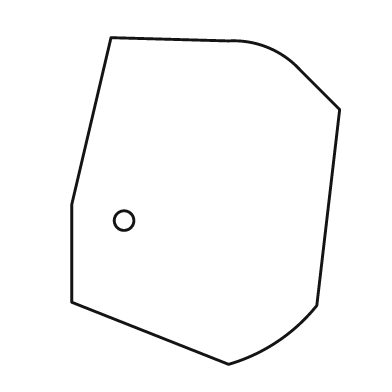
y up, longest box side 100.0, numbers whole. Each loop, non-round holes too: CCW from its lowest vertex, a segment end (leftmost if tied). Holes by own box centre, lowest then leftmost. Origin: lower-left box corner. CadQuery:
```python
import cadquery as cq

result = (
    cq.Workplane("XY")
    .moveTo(48.0, 0.0)
    .threePointArc((63.0, 7.0), (75.0, 18.0))
    .lineTo(82.0, 78.0)
    .lineTo(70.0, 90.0)
    .threePointArc((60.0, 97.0), (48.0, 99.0))
    .lineTo(12.0, 100.0)
    .lineTo(0.0, 49.0)
    .lineTo(0.0, 19.0)
    .close()
    .moveTo(16.0, 44.0)
    .circle(3.0)
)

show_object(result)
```